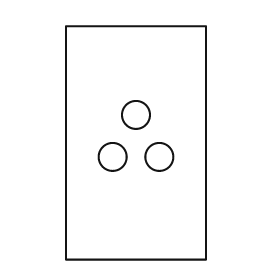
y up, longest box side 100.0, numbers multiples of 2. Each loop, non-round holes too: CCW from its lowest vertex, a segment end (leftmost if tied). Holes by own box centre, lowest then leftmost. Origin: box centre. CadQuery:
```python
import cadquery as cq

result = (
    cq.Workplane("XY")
    .moveTo(-30.0, -50.0)
    .lineTo(30.0, -50.0)
    .lineTo(30.0, 50.0)
    .lineTo(-30.0, 50.0)
    .close()
    .moveTo(-10.0, -6.0)
    .circle(6.0)
    .moveTo(10.0, -6.0)
    .circle(6.0)
    .moveTo(0.0, 12.0)
    .circle(6.0)
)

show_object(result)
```